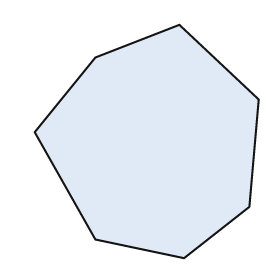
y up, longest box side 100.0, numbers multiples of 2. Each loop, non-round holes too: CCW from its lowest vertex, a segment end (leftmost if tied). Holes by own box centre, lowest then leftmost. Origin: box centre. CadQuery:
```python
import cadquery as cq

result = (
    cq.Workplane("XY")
    .moveTo(16.0, -50.0)
    .lineTo(44.0, -28.0)
    .lineTo(48.0, 18.0)
    .lineTo(14.0, 50.0)
    .lineTo(-22.0, 36.0)
    .lineTo(-48.0, 4.0)
    .lineTo(-22.0, -42.0)
    .close()
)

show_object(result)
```